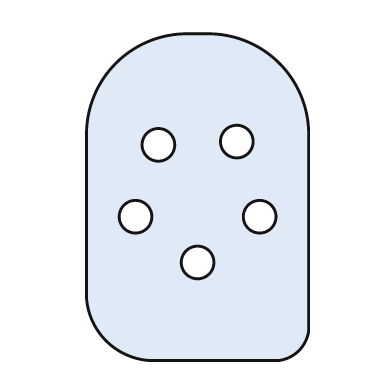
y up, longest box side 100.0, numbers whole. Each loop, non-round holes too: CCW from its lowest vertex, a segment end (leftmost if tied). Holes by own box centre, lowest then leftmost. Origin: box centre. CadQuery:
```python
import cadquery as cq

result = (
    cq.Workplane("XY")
    .moveTo(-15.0, -50.0)
    .lineTo(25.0, -50.0)
    .threePointArc((31.0, -47.0), (34.0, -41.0))
    .lineTo(34.0, 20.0)
    .threePointArc((25.0, 41.0), (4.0, 50.0))
    .lineTo(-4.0, 50.0)
    .threePointArc((-25.0, 41.0), (-34.0, 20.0))
    .lineTo(-34.0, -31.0)
    .threePointArc((-28.0, -44.0), (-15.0, -50.0))
    .close()
    .moveTo(0.0, -20.0)
    .circle(5.0)
    .moveTo(-19.0, -6.0)
    .circle(5.0)
    .moveTo(19.0, -6.0)
    .circle(5.0)
    .moveTo(-12.0, 16.0)
    .circle(5.0)
    .moveTo(12.0, 17.0)
    .circle(5.0)
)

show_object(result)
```